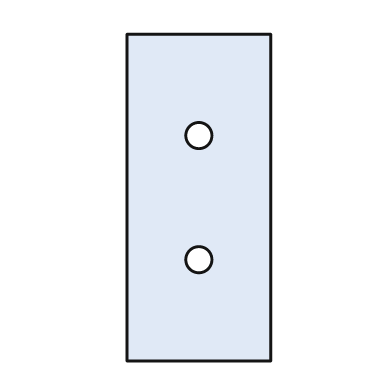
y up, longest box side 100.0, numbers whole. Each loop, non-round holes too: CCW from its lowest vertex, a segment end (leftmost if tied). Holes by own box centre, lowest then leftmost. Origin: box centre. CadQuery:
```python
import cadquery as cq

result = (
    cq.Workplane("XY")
    .moveTo(-22.0, -50.0)
    .lineTo(22.0, -50.0)
    .lineTo(22.0, 50.0)
    .lineTo(-22.0, 50.0)
    .close()
    .moveTo(0.0, -19.0)
    .circle(4.0)
    .moveTo(0.0, 19.0)
    .circle(4.0)
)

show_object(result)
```